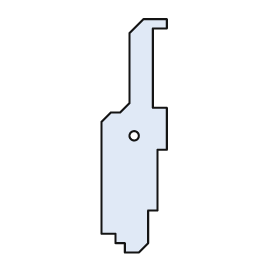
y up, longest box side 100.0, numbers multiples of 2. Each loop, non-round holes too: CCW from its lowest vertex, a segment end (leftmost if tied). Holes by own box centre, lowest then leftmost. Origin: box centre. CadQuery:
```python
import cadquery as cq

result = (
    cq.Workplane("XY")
    .moveTo(-4.0, -50.0)
    .lineTo(2.0, -50.0)
    .lineTo(6.0, -46.0)
    .lineTo(6.0, -32.0)
    .lineTo(10.0, -32.0)
    .lineTo(10.0, -6.0)
    .lineTo(14.0, -6.0)
    .lineTo(14.0, 12.0)
    .lineTo(8.0, 12.0)
    .lineTo(8.0, 46.0)
    .lineTo(14.0, 46.0)
    .lineTo(14.0, 50.0)
    .lineTo(4.0, 50.0)
    .lineTo(-2.0, 44.0)
    .lineTo(-2.0, 14.0)
    .lineTo(-6.0, 10.0)
    .lineTo(-10.0, 10.0)
    .lineTo(-14.0, 6.0)
    .lineTo(-14.0, -42.0)
    .lineTo(-8.0, -42.0)
    .lineTo(-8.0, -46.0)
    .lineTo(-4.0, -46.0)
    .close()
    .moveTo(0.0, 0.0)
    .circle(2.0)
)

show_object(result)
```